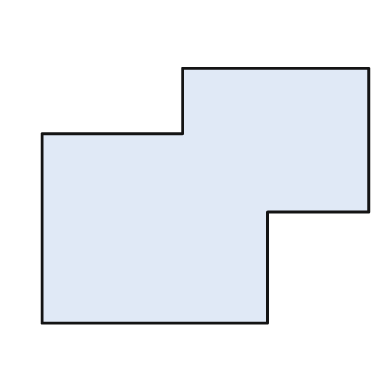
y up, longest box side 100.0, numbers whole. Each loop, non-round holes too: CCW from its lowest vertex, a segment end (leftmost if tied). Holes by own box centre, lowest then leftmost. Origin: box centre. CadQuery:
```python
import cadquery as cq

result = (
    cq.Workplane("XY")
    .moveTo(-50.0, -39.0)
    .lineTo(19.0, -39.0)
    .lineTo(19.0, -5.0)
    .lineTo(50.0, -5.0)
    .lineTo(50.0, 39.0)
    .lineTo(-7.0, 39.0)
    .lineTo(-7.0, 19.0)
    .lineTo(-50.0, 19.0)
    .close()
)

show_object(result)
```